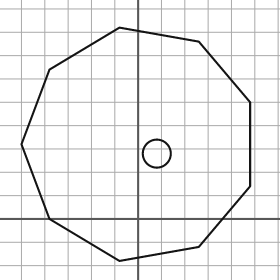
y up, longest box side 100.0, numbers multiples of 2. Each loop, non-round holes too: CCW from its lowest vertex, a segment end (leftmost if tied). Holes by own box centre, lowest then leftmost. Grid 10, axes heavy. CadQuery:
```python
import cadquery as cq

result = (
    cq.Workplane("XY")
    .moveTo(-8.0, -18.0)
    .lineTo(26.0, -12.0)
    .lineTo(48.0, 14.0)
    .lineTo(48.0, 50.0)
    .lineTo(26.0, 76.0)
    .lineTo(-8.0, 82.0)
    .lineTo(-38.0, 64.0)
    .lineTo(-50.0, 32.0)
    .lineTo(-38.0, 0.0)
    .close()
    .moveTo(8.0, 28.0)
    .circle(6.0)
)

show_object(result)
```